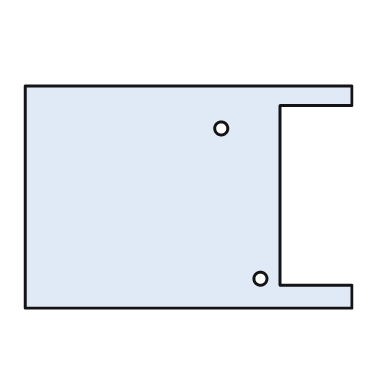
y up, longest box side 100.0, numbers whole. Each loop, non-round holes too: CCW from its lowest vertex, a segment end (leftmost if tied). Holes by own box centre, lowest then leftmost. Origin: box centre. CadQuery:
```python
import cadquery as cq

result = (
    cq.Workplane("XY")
    .moveTo(-50.0, -34.0)
    .lineTo(50.0, -34.0)
    .lineTo(50.0, -27.0)
    .lineTo(28.0, -27.0)
    .lineTo(28.0, 28.0)
    .lineTo(50.0, 28.0)
    .lineTo(50.0, 34.0)
    .lineTo(-50.0, 34.0)
    .close()
    .moveTo(22.0, -25.0)
    .circle(2.0)
    .moveTo(10.0, 21.0)
    .circle(2.0)
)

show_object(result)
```